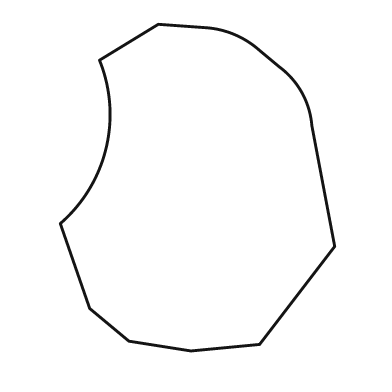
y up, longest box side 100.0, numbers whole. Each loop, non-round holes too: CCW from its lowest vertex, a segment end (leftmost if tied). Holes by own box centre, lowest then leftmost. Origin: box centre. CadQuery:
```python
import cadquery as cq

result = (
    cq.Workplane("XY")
    .moveTo(-2.0, -50.0)
    .lineTo(19.0, -48.0)
    .lineTo(42.0, -18.0)
    .lineTo(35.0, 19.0)
    .threePointArc((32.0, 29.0), (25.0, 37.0))
    .lineTo(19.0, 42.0)
    .threePointArc((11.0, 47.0), (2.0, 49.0))
    .lineTo(-12.0, 50.0)
    .lineTo(-30.0, 39.0)
    .threePointArc((-28.0, 12.0), (-42.0, -11.0))
    .lineTo(-33.0, -37.0)
    .lineTo(-21.0, -47.0)
    .close()
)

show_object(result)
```